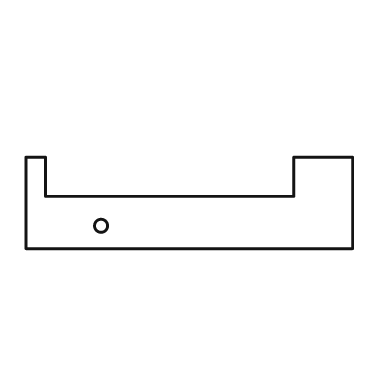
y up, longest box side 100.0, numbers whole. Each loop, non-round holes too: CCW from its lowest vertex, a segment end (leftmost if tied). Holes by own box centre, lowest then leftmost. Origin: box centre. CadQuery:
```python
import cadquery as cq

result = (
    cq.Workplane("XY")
    .moveTo(-50.0, -14.0)
    .lineTo(50.0, -14.0)
    .lineTo(50.0, 14.0)
    .lineTo(32.0, 14.0)
    .lineTo(32.0, 2.0)
    .lineTo(-44.0, 2.0)
    .lineTo(-44.0, 14.0)
    .lineTo(-50.0, 14.0)
    .close()
    .moveTo(-27.0, -7.0)
    .circle(2.0)
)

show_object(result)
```